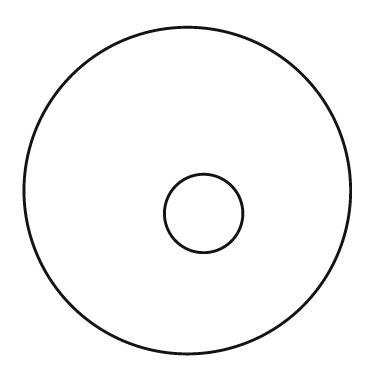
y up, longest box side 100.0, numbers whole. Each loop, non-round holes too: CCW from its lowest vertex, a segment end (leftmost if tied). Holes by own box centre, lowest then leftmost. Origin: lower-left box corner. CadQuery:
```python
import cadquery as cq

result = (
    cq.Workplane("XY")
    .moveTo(50.0, 50.0)
    .circle(50.0)
    .moveTo(55.0, 43.0)
    .circle(12.0)
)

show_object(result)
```